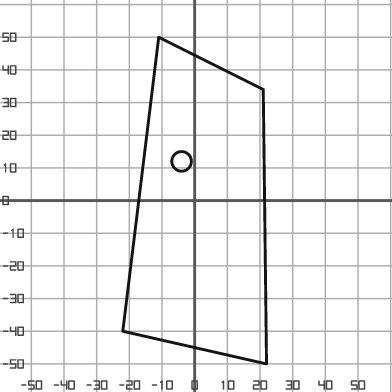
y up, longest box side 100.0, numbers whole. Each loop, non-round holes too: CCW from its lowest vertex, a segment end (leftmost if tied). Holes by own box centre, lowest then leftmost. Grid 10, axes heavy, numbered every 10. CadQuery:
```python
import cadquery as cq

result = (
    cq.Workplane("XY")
    .moveTo(22.0, -50.0)
    .lineTo(21.0, 34.0)
    .lineTo(-11.0, 50.0)
    .lineTo(-22.0, -40.0)
    .close()
    .moveTo(-4.0, 12.0)
    .circle(3.0)
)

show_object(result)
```